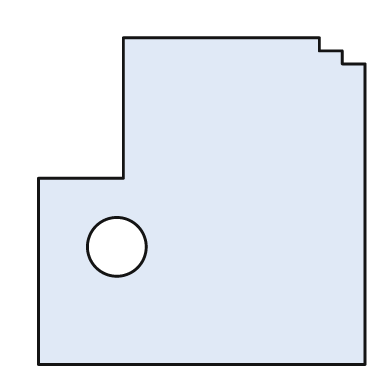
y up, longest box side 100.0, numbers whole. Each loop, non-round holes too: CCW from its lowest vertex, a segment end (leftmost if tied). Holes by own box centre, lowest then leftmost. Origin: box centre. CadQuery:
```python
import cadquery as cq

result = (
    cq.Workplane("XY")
    .moveTo(-50.0, -50.0)
    .lineTo(50.0, -50.0)
    .lineTo(50.0, 42.0)
    .lineTo(43.0, 42.0)
    .lineTo(43.0, 46.0)
    .lineTo(36.0, 46.0)
    .lineTo(36.0, 50.0)
    .lineTo(-24.0, 50.0)
    .lineTo(-24.0, 7.0)
    .lineTo(-50.0, 7.0)
    .close()
    .moveTo(-26.0, -14.0)
    .circle(9.0)
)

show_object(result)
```